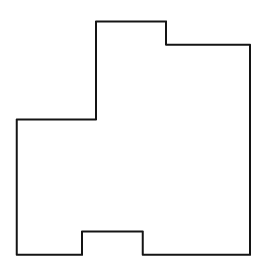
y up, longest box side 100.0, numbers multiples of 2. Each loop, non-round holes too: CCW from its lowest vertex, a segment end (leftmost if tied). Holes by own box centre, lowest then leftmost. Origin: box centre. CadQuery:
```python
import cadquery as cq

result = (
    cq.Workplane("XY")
    .moveTo(-50.0, -50.0)
    .lineTo(-22.0, -50.0)
    .lineTo(-22.0, -40.0)
    .lineTo(4.0, -40.0)
    .lineTo(4.0, -50.0)
    .lineTo(50.0, -50.0)
    .lineTo(50.0, 40.0)
    .lineTo(14.0, 40.0)
    .lineTo(14.0, 50.0)
    .lineTo(-16.0, 50.0)
    .lineTo(-16.0, 8.0)
    .lineTo(-50.0, 8.0)
    .close()
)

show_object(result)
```